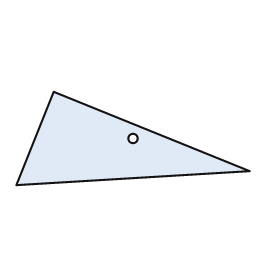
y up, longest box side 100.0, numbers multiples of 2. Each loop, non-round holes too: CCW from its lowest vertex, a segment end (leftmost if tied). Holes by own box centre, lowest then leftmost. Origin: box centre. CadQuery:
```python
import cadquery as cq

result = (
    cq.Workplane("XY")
    .moveTo(-50.0, -20.0)
    .lineTo(50.0, -14.0)
    .lineTo(-34.0, 20.0)
    .close()
    .moveTo(0.0, 0.0)
    .circle(2.0)
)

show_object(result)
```